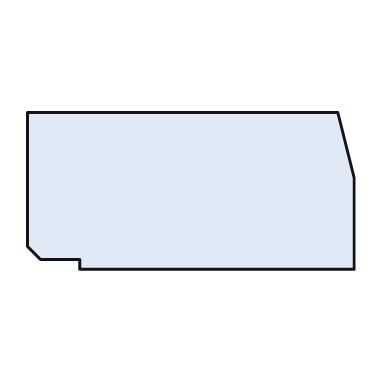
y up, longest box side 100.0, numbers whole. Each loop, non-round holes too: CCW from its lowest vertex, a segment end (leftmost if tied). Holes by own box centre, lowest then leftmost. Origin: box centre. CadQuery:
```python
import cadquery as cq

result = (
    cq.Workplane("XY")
    .moveTo(-34.0, -24.0)
    .lineTo(50.0, -24.0)
    .lineTo(50.0, 4.0)
    .lineTo(45.0, 24.0)
    .lineTo(-50.0, 24.0)
    .lineTo(-50.0, -17.0)
    .lineTo(-46.0, -21.0)
    .lineTo(-34.0, -21.0)
    .close()
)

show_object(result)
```